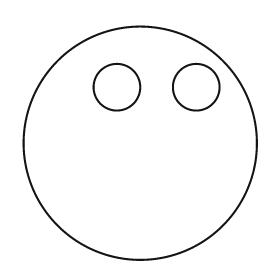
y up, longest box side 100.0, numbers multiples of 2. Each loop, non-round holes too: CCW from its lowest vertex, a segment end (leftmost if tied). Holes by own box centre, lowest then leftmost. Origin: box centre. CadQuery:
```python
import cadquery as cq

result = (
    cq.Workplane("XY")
    .moveTo(0.0, 0.0)
    .circle(50.0)
    .moveTo(-10.0, 24.0)
    .circle(10.0)
    .moveTo(24.0, 24.0)
    .circle(10.0)
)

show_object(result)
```